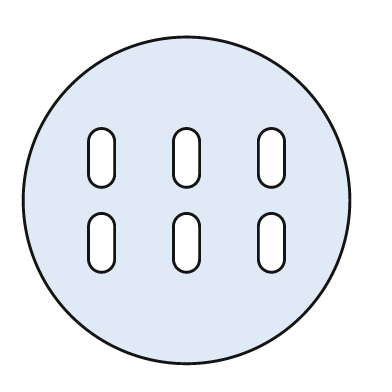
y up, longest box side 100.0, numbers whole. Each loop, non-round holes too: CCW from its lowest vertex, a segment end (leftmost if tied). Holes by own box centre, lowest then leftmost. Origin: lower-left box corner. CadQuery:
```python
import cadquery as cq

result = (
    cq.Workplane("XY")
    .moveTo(50.0, 50.0)
    .circle(50.0)
    .moveTo(20.0, 32.0)
    .threePointArc((24.0, 28.0), (28.0, 32.0))
    .lineTo(28.0, 42.0)
    .threePointArc((24.0, 46.0), (20.0, 42.0))
    .close()
    .moveTo(46.0, 32.0)
    .threePointArc((50.0, 28.0), (54.0, 32.0))
    .lineTo(54.0, 42.0)
    .threePointArc((50.0, 46.0), (46.0, 42.0))
    .close()
    .moveTo(72.0, 32.0)
    .threePointArc((76.0, 28.0), (80.0, 32.0))
    .lineTo(80.0, 42.0)
    .threePointArc((76.0, 46.0), (72.0, 42.0))
    .close()
    .moveTo(20.0, 58.0)
    .threePointArc((24.0, 54.0), (28.0, 58.0))
    .lineTo(28.0, 68.0)
    .threePointArc((24.0, 72.0), (20.0, 68.0))
    .close()
    .moveTo(46.0, 58.0)
    .threePointArc((50.0, 54.0), (54.0, 58.0))
    .lineTo(54.0, 68.0)
    .threePointArc((50.0, 72.0), (46.0, 68.0))
    .close()
    .moveTo(72.0, 58.0)
    .threePointArc((76.0, 54.0), (80.0, 58.0))
    .lineTo(80.0, 68.0)
    .threePointArc((76.0, 72.0), (72.0, 68.0))
    .close()
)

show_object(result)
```